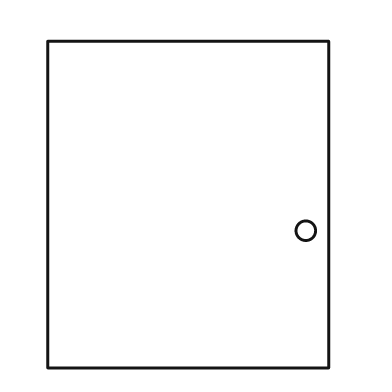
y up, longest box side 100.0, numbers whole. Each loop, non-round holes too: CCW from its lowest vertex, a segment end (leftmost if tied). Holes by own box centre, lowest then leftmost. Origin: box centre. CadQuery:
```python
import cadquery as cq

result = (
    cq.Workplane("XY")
    .moveTo(-43.0, -50.0)
    .lineTo(43.0, -50.0)
    .lineTo(43.0, 50.0)
    .lineTo(-43.0, 50.0)
    .close()
    .moveTo(36.0, -8.0)
    .circle(3.0)
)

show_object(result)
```